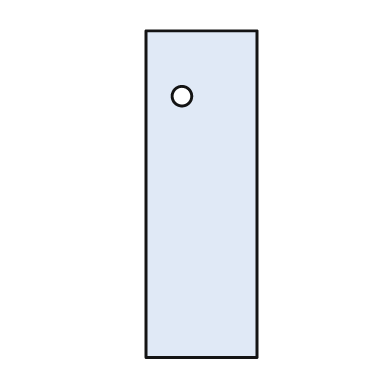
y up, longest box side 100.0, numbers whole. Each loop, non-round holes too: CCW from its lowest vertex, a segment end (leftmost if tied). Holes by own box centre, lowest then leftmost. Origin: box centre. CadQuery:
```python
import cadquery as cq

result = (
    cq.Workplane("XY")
    .moveTo(-17.0, -50.0)
    .lineTo(17.0, -50.0)
    .lineTo(17.0, 50.0)
    .lineTo(-17.0, 50.0)
    .close()
    .moveTo(-6.0, 30.0)
    .circle(3.0)
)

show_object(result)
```